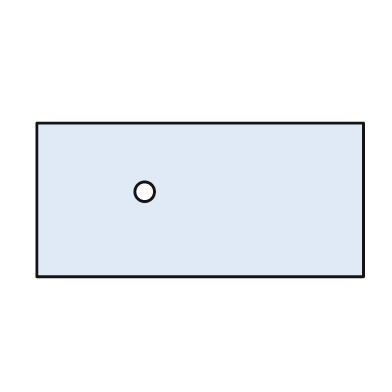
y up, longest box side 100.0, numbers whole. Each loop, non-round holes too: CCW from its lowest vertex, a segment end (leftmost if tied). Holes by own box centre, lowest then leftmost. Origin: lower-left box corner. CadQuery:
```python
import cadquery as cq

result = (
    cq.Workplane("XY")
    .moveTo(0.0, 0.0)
    .lineTo(100.0, 0.0)
    .lineTo(100.0, 47.0)
    .lineTo(0.0, 47.0)
    .close()
    .moveTo(33.0, 26.0)
    .circle(3.0)
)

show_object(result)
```